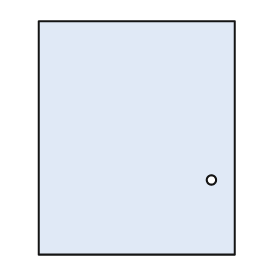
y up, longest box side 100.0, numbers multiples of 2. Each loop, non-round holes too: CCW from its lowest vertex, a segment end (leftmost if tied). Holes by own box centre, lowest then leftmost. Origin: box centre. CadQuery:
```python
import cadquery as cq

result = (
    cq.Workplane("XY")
    .moveTo(-42.0, -50.0)
    .lineTo(42.0, -50.0)
    .lineTo(42.0, 50.0)
    .lineTo(-42.0, 50.0)
    .close()
    .moveTo(32.0, -18.0)
    .circle(2.0)
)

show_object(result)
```